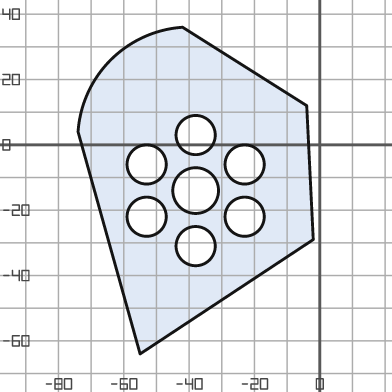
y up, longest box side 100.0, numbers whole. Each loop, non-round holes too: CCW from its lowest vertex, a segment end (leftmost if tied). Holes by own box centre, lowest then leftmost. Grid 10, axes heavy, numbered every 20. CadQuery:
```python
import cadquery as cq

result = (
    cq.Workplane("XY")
    .moveTo(-55.0, -64.0)
    .lineTo(-2.0, -29.0)
    .lineTo(-4.0, 12.0)
    .lineTo(-42.0, 36.0)
    .threePointArc((-64.0, 26.0), (-74.0, 4.0))
    .close()
    .moveTo(-38.0, -31.0)
    .circle(6.0)
    .moveTo(-53.0, -22.0)
    .circle(6.0)
    .moveTo(-23.0, -22.0)
    .circle(6.0)
    .moveTo(-38.0, -14.0)
    .circle(7.0)
    .moveTo(-53.0, -6.0)
    .circle(6.0)
    .moveTo(-23.0, -6.0)
    .circle(6.0)
    .moveTo(-38.0, 3.0)
    .circle(6.0)
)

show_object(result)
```